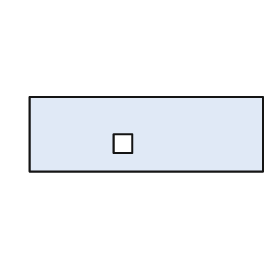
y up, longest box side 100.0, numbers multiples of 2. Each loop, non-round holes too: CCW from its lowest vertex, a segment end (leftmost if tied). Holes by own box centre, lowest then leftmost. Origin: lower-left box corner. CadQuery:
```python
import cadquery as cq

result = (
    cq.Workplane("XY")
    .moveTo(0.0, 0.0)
    .lineTo(100.0, 0.0)
    .lineTo(100.0, 32.0)
    .lineTo(0.0, 32.0)
    .close()
    .moveTo(36.0, 8.0)
    .lineTo(44.0, 8.0)
    .lineTo(44.0, 16.0)
    .lineTo(36.0, 16.0)
    .close()
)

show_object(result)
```